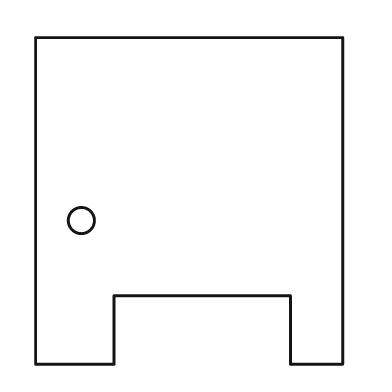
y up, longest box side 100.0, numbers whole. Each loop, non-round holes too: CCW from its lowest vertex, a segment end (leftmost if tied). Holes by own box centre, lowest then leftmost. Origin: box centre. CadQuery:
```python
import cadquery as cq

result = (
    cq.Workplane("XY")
    .moveTo(-47.0, -50.0)
    .lineTo(-23.0, -50.0)
    .lineTo(-23.0, -29.0)
    .lineTo(31.0, -29.0)
    .lineTo(31.0, -50.0)
    .lineTo(47.0, -50.0)
    .lineTo(47.0, 50.0)
    .lineTo(-47.0, 50.0)
    .close()
    .moveTo(-33.0, -6.0)
    .circle(4.0)
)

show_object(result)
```